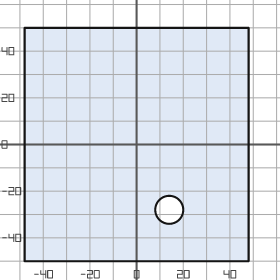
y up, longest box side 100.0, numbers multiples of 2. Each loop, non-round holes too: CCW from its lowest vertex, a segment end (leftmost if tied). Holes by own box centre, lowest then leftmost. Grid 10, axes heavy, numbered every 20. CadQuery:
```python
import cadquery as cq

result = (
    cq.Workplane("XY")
    .moveTo(-48.0, -50.0)
    .lineTo(48.0, -50.0)
    .lineTo(48.0, 50.0)
    .lineTo(-48.0, 50.0)
    .close()
    .moveTo(14.0, -28.0)
    .circle(6.0)
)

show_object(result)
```